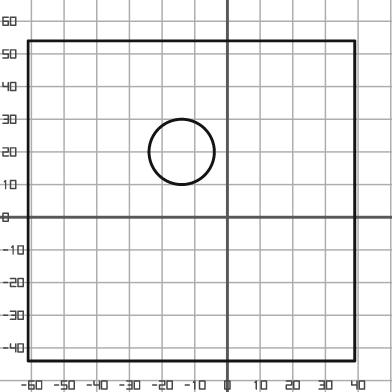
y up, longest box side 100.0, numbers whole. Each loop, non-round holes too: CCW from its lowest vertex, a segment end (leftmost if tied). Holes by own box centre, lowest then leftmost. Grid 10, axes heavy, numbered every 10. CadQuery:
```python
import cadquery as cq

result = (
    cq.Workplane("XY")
    .moveTo(-61.0, -44.0)
    .lineTo(39.0, -44.0)
    .lineTo(39.0, 54.0)
    .lineTo(-61.0, 54.0)
    .close()
    .moveTo(-14.0, 20.0)
    .circle(10.0)
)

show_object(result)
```